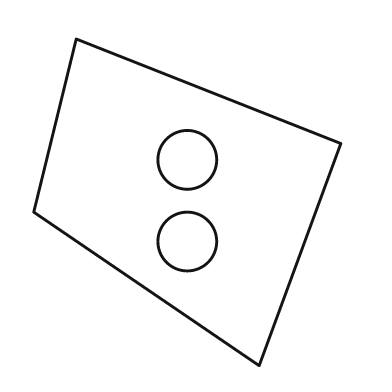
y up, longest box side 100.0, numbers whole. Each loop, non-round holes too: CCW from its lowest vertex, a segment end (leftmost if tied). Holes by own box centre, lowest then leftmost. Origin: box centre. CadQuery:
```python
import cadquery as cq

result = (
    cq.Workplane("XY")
    .moveTo(22.0, -50.0)
    .lineTo(47.0, 18.0)
    .lineTo(-34.0, 50.0)
    .lineTo(-47.0, -3.0)
    .close()
    .moveTo(0.0, -12.0)
    .circle(9.0)
    .moveTo(0.0, 13.0)
    .circle(9.0)
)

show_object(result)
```